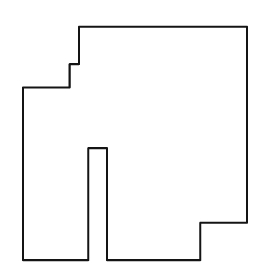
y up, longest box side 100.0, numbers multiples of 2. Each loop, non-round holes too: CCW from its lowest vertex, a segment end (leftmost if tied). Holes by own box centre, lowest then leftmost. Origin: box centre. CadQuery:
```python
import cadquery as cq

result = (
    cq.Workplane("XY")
    .moveTo(-48.0, -50.0)
    .lineTo(-20.0, -50.0)
    .lineTo(-20.0, -2.0)
    .lineTo(-12.0, -2.0)
    .lineTo(-12.0, -50.0)
    .lineTo(28.0, -50.0)
    .lineTo(28.0, -34.0)
    .lineTo(48.0, -34.0)
    .lineTo(48.0, 50.0)
    .lineTo(-24.0, 50.0)
    .lineTo(-24.0, 34.0)
    .lineTo(-28.0, 34.0)
    .lineTo(-28.0, 24.0)
    .lineTo(-48.0, 24.0)
    .close()
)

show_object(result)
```